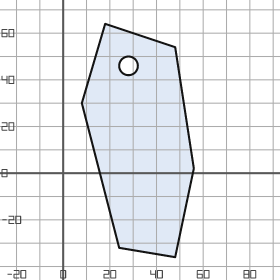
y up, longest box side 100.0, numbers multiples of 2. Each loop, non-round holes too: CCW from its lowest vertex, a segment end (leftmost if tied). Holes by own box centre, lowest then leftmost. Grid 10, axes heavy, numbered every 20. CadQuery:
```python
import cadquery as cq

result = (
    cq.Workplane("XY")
    .moveTo(48.0, -36.0)
    .lineTo(56.0, 2.0)
    .lineTo(48.0, 54.0)
    .lineTo(18.0, 64.0)
    .lineTo(8.0, 30.0)
    .lineTo(24.0, -32.0)
    .close()
    .moveTo(28.0, 46.0)
    .circle(4.0)
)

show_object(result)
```